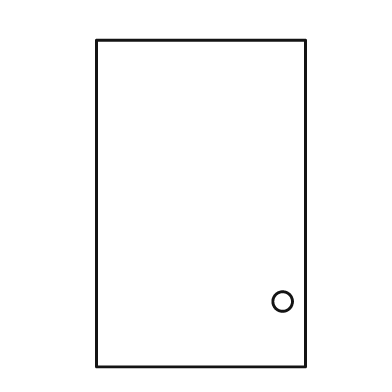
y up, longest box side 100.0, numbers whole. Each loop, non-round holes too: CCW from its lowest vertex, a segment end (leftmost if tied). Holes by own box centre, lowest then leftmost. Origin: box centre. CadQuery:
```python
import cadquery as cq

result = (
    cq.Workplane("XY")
    .moveTo(-32.0, -50.0)
    .lineTo(32.0, -50.0)
    .lineTo(32.0, 50.0)
    .lineTo(-32.0, 50.0)
    .close()
    .moveTo(25.0, -30.0)
    .circle(3.0)
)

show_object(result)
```